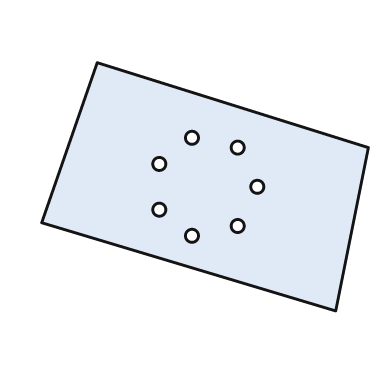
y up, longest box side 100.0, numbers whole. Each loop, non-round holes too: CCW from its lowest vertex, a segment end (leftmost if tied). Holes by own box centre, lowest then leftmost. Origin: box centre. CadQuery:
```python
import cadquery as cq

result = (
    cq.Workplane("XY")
    .moveTo(40.0, -38.0)
    .lineTo(50.0, 12.0)
    .lineTo(-33.0, 38.0)
    .lineTo(-50.0, -11.0)
    .close()
    .moveTo(-4.0, -15.0)
    .circle(2.0)
    .moveTo(10.0, -12.0)
    .circle(2.0)
    .moveTo(-14.0, -7.0)
    .circle(2.0)
    .moveTo(16.0, 0.0)
    .circle(2.0)
    .moveTo(-14.0, 7.0)
    .circle(2.0)
    .moveTo(10.0, 12.0)
    .circle(2.0)
    .moveTo(-4.0, 15.0)
    .circle(2.0)
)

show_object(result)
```